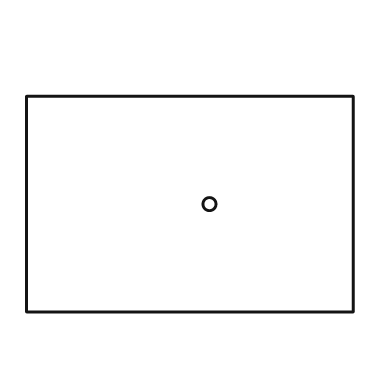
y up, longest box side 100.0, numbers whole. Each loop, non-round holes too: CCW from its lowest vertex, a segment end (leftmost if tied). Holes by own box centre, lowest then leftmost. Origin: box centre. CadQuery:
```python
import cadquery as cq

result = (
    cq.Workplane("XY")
    .moveTo(-50.0, -33.0)
    .lineTo(50.0, -33.0)
    .lineTo(50.0, 33.0)
    .lineTo(-50.0, 33.0)
    .close()
    .moveTo(6.0, 0.0)
    .circle(2.0)
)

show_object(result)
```